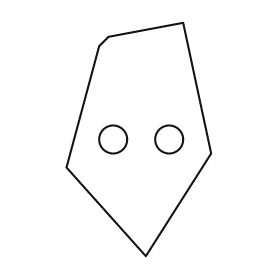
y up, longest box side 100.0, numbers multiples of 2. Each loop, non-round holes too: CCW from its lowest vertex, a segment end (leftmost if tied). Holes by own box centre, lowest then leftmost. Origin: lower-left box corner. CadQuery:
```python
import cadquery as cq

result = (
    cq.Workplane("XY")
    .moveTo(34.0, 0.0)
    .lineTo(62.0, 44.0)
    .lineTo(50.0, 100.0)
    .lineTo(18.0, 94.0)
    .lineTo(14.0, 90.0)
    .lineTo(0.0, 38.0)
    .close()
    .moveTo(20.0, 50.0)
    .circle(6.0)
    .moveTo(44.0, 50.0)
    .circle(6.0)
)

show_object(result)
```